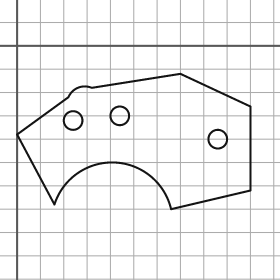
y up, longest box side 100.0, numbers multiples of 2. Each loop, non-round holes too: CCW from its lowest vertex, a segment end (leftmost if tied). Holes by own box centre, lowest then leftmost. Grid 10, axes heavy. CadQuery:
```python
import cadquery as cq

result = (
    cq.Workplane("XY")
    .moveTo(66.0, -70.0)
    .lineTo(100.0, -62.0)
    .lineTo(100.0, -26.0)
    .lineTo(70.0, -12.0)
    .lineTo(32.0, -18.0)
    .threePointArc((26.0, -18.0), (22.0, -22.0))
    .lineTo(0.0, -38.0)
    .lineTo(16.0, -68.0)
    .threePointArc((42.0, -50.0), (66.0, -70.0))
    .close()
    .moveTo(86.0, -40.0)
    .circle(4.0)
    .moveTo(24.0, -32.0)
    .circle(4.0)
    .moveTo(44.0, -30.0)
    .circle(4.0)
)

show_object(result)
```